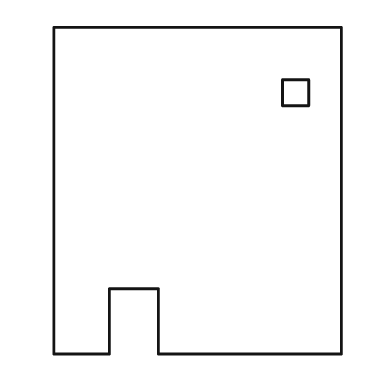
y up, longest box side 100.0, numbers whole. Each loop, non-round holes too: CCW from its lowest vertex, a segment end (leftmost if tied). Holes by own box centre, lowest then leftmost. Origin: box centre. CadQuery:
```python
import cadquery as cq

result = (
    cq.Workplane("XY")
    .moveTo(-44.0, -50.0)
    .lineTo(-27.0, -50.0)
    .lineTo(-27.0, -30.0)
    .lineTo(-12.0, -30.0)
    .lineTo(-12.0, -50.0)
    .lineTo(44.0, -50.0)
    .lineTo(44.0, 50.0)
    .lineTo(-44.0, 50.0)
    .close()
    .moveTo(26.0, 26.0)
    .lineTo(34.0, 26.0)
    .lineTo(34.0, 34.0)
    .lineTo(26.0, 34.0)
    .close()
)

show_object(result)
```